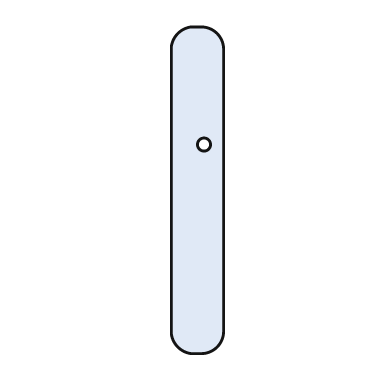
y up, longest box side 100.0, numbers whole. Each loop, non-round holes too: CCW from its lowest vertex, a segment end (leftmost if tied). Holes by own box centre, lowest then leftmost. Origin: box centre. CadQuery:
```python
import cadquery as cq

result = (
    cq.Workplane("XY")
    .moveTo(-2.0, -50.0)
    .lineTo(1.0, -50.0)
    .threePointArc((6.0, -48.0), (8.0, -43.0))
    .lineTo(8.0, 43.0)
    .threePointArc((6.0, 48.0), (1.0, 50.0))
    .lineTo(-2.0, 50.0)
    .threePointArc((-6.0, 48.0), (-8.0, 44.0))
    .lineTo(-8.0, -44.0)
    .threePointArc((-6.0, -48.0), (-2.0, -50.0))
    .close()
    .moveTo(2.0, 14.0)
    .circle(2.0)
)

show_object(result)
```